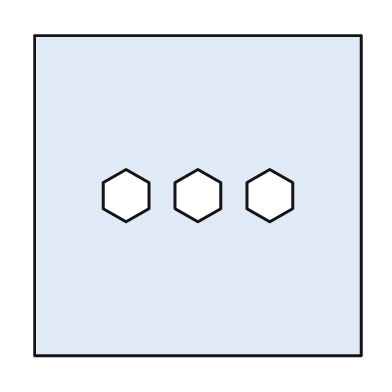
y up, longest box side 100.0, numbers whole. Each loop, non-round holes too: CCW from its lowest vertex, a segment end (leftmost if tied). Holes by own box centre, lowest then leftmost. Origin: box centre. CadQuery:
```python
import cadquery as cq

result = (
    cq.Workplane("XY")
    .moveTo(-50.0, -49.0)
    .lineTo(50.0, -49.0)
    .lineTo(50.0, 49.0)
    .lineTo(-50.0, 49.0)
    .close()
    .moveTo(-22.0, -8.0)
    .lineTo(-15.0, -4.0)
    .lineTo(-15.0, 4.0)
    .lineTo(-22.0, 8.0)
    .lineTo(-29.0, 4.0)
    .lineTo(-29.0, -4.0)
    .close()
    .moveTo(0.0, -8.0)
    .lineTo(7.0, -4.0)
    .lineTo(7.0, 4.0)
    .lineTo(0.0, 8.0)
    .lineTo(-7.0, 4.0)
    .lineTo(-7.0, -4.0)
    .close()
    .moveTo(22.0, -8.0)
    .lineTo(29.0, -4.0)
    .lineTo(29.0, 4.0)
    .lineTo(22.0, 8.0)
    .lineTo(15.0, 4.0)
    .lineTo(15.0, -4.0)
    .close()
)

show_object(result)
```